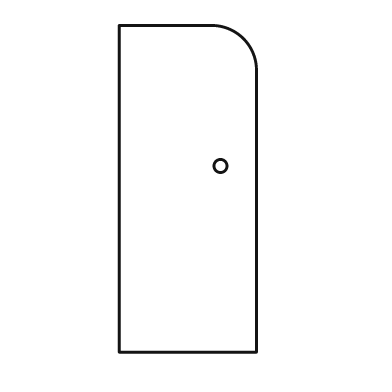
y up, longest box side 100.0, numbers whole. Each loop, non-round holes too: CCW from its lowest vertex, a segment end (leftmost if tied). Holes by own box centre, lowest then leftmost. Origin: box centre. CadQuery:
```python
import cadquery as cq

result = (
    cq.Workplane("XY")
    .moveTo(-21.0, -50.0)
    .lineTo(21.0, -50.0)
    .lineTo(21.0, 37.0)
    .threePointArc((17.0, 46.0), (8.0, 50.0))
    .lineTo(-21.0, 50.0)
    .close()
    .moveTo(10.0, 7.0)
    .circle(2.0)
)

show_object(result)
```